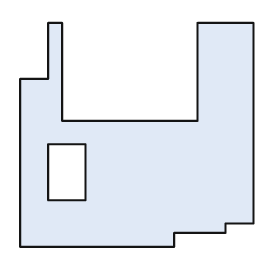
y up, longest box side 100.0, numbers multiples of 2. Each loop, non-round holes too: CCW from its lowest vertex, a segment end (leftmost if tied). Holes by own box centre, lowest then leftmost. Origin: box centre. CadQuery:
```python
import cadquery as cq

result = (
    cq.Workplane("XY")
    .moveTo(-50.0, -48.0)
    .lineTo(16.0, -48.0)
    .lineTo(16.0, -42.0)
    .lineTo(38.0, -42.0)
    .lineTo(38.0, -38.0)
    .lineTo(50.0, -38.0)
    .lineTo(50.0, 48.0)
    .lineTo(26.0, 48.0)
    .lineTo(26.0, 6.0)
    .lineTo(-32.0, 6.0)
    .lineTo(-32.0, 48.0)
    .lineTo(-38.0, 48.0)
    .lineTo(-38.0, 24.0)
    .lineTo(-50.0, 24.0)
    .close()
    .moveTo(-38.0, -28.0)
    .lineTo(-22.0, -28.0)
    .lineTo(-22.0, -4.0)
    .lineTo(-38.0, -4.0)
    .close()
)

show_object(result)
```